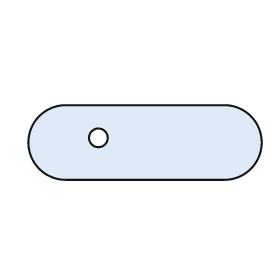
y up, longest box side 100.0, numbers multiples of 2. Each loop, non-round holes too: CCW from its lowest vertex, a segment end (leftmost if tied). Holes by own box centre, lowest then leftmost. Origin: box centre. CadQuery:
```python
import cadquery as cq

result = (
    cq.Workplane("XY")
    .moveTo(-34.0, -16.0)
    .lineTo(34.0, -16.0)
    .threePointArc((50.0, 0.0), (34.0, 16.0))
    .lineTo(-34.0, 16.0)
    .threePointArc((-50.0, 0.0), (-34.0, -16.0))
    .close()
    .moveTo(-20.0, 2.0)
    .circle(4.0)
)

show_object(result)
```